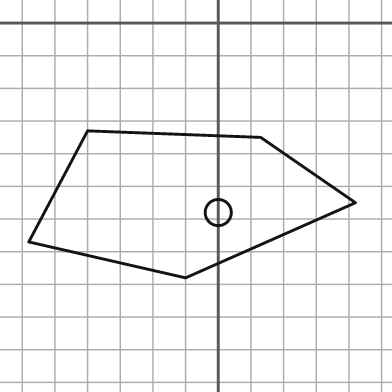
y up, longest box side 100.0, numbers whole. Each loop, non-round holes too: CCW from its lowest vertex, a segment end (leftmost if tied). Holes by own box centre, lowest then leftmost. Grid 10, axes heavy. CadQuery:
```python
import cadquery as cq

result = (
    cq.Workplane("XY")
    .moveTo(-10.0, -78.0)
    .lineTo(42.0, -55.0)
    .lineTo(13.0, -35.0)
    .lineTo(-40.0, -33.0)
    .lineTo(-58.0, -67.0)
    .close()
    .moveTo(0.0, -58.0)
    .circle(4.0)
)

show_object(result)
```